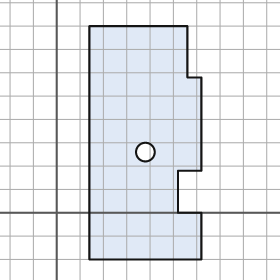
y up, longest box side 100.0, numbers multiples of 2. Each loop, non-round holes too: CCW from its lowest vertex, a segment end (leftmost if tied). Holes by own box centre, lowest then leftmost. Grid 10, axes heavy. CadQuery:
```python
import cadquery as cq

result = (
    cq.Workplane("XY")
    .moveTo(14.0, -20.0)
    .lineTo(62.0, -20.0)
    .lineTo(62.0, 0.0)
    .lineTo(52.0, 0.0)
    .lineTo(52.0, 18.0)
    .lineTo(62.0, 18.0)
    .lineTo(62.0, 58.0)
    .lineTo(56.0, 58.0)
    .lineTo(56.0, 80.0)
    .lineTo(14.0, 80.0)
    .close()
    .moveTo(38.0, 26.0)
    .circle(4.0)
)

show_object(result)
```